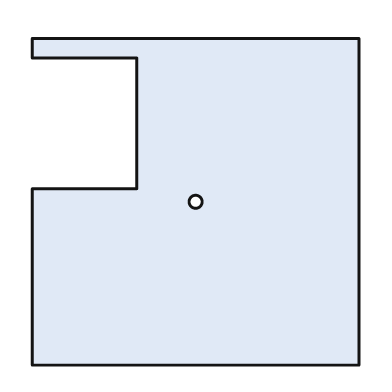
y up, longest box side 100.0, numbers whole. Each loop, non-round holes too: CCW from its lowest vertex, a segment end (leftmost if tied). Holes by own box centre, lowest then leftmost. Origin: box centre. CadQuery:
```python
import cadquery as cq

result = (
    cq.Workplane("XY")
    .moveTo(-50.0, -50.0)
    .lineTo(50.0, -50.0)
    .lineTo(50.0, 50.0)
    .lineTo(-50.0, 50.0)
    .lineTo(-50.0, 44.0)
    .lineTo(-18.0, 44.0)
    .lineTo(-18.0, 4.0)
    .lineTo(-50.0, 4.0)
    .close()
    .moveTo(0.0, 0.0)
    .circle(2.0)
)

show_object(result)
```